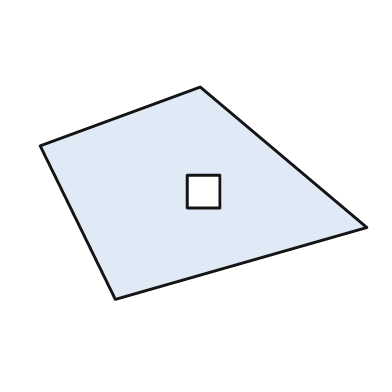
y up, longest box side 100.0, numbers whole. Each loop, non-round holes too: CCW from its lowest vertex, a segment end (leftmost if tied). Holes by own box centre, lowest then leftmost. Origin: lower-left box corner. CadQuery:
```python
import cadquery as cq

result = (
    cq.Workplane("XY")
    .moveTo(23.0, 0.0)
    .lineTo(100.0, 22.0)
    .lineTo(49.0, 65.0)
    .lineTo(0.0, 47.0)
    .close()
    .moveTo(45.0, 28.0)
    .lineTo(55.0, 28.0)
    .lineTo(55.0, 38.0)
    .lineTo(45.0, 38.0)
    .close()
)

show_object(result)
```